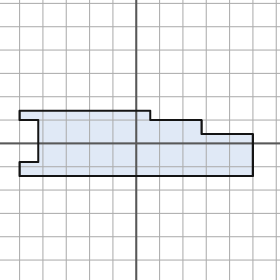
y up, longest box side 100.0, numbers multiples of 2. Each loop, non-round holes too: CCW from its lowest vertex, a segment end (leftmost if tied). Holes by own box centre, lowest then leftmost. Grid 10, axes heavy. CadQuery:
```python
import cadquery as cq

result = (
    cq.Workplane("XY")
    .moveTo(-50.0, -14.0)
    .lineTo(50.0, -14.0)
    .lineTo(50.0, 4.0)
    .lineTo(28.0, 4.0)
    .lineTo(28.0, 10.0)
    .lineTo(6.0, 10.0)
    .lineTo(6.0, 14.0)
    .lineTo(-50.0, 14.0)
    .lineTo(-50.0, 10.0)
    .lineTo(-42.0, 10.0)
    .lineTo(-42.0, -8.0)
    .lineTo(-50.0, -8.0)
    .close()
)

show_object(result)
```